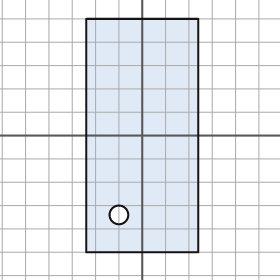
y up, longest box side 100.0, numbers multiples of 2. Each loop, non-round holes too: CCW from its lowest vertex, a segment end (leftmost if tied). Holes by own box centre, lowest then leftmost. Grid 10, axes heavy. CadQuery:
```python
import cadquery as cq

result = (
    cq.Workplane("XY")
    .moveTo(-24.0, -50.0)
    .lineTo(24.0, -50.0)
    .lineTo(24.0, 50.0)
    .lineTo(-24.0, 50.0)
    .close()
    .moveTo(-10.0, -34.0)
    .circle(4.0)
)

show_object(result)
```